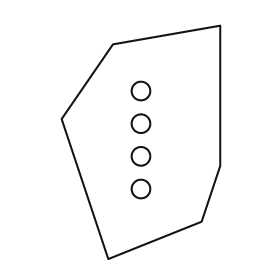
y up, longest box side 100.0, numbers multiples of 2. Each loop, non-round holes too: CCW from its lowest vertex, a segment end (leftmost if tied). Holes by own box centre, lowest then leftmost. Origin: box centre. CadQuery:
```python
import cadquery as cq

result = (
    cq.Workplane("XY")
    .moveTo(-14.0, -50.0)
    .lineTo(26.0, -34.0)
    .lineTo(34.0, -10.0)
    .lineTo(34.0, 50.0)
    .lineTo(-12.0, 42.0)
    .lineTo(-34.0, 10.0)
    .close()
    .moveTo(0.0, -20.0)
    .circle(4.0)
    .moveTo(0.0, -6.0)
    .circle(4.0)
    .moveTo(0.0, 8.0)
    .circle(4.0)
    .moveTo(0.0, 22.0)
    .circle(4.0)
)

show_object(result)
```